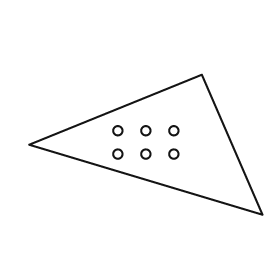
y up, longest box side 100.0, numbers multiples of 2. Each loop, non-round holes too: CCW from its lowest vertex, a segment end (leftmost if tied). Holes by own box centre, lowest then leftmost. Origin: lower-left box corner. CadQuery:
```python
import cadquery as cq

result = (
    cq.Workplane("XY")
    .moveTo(100.0, 0.0)
    .lineTo(74.0, 60.0)
    .lineTo(0.0, 30.0)
    .close()
    .moveTo(38.0, 26.0)
    .circle(2.0)
    .moveTo(50.0, 26.0)
    .circle(2.0)
    .moveTo(62.0, 26.0)
    .circle(2.0)
    .moveTo(38.0, 36.0)
    .circle(2.0)
    .moveTo(50.0, 36.0)
    .circle(2.0)
    .moveTo(62.0, 36.0)
    .circle(2.0)
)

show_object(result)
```